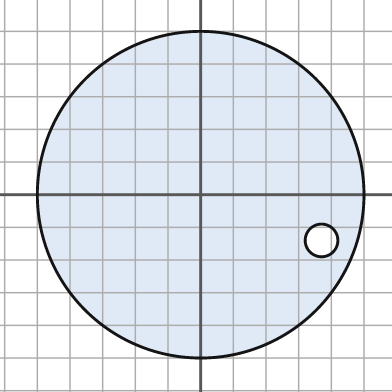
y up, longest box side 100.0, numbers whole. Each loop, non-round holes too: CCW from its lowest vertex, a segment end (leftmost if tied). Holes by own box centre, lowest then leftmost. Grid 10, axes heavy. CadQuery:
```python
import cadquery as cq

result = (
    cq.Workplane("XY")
    .moveTo(0.0, 0.0)
    .circle(50.0)
    .moveTo(37.0, -14.0)
    .circle(5.0)
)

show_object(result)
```